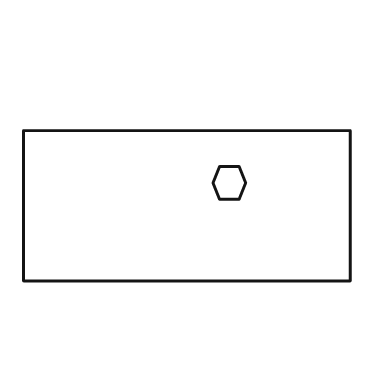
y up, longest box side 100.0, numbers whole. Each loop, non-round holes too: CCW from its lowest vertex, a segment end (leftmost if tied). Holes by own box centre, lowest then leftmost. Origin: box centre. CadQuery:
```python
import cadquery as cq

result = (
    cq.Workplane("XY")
    .moveTo(-50.0, -23.0)
    .lineTo(50.0, -23.0)
    .lineTo(50.0, 23.0)
    .lineTo(-50.0, 23.0)
    .close()
    .moveTo(10.0, 2.0)
    .lineTo(16.0, 2.0)
    .lineTo(18.0, 7.0)
    .lineTo(16.0, 12.0)
    .lineTo(10.0, 12.0)
    .lineTo(8.0, 7.0)
    .close()
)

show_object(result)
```